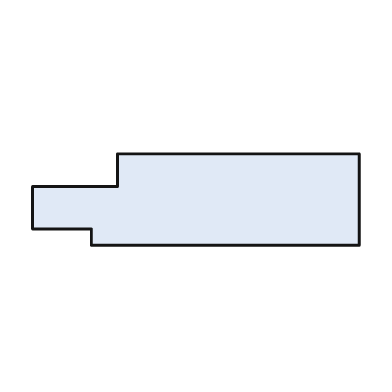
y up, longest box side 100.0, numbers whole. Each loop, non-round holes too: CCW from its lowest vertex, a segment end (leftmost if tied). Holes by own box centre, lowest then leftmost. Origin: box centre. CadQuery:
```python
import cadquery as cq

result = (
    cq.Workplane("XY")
    .moveTo(-32.0, -14.0)
    .lineTo(50.0, -14.0)
    .lineTo(50.0, 14.0)
    .lineTo(-24.0, 14.0)
    .lineTo(-24.0, 4.0)
    .lineTo(-50.0, 4.0)
    .lineTo(-50.0, -9.0)
    .lineTo(-32.0, -9.0)
    .close()
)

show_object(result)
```